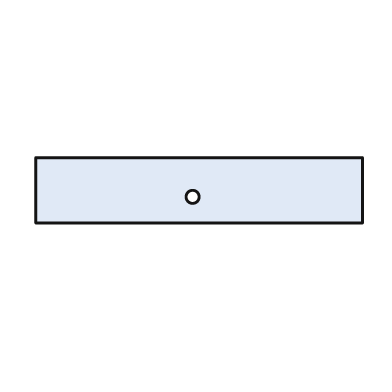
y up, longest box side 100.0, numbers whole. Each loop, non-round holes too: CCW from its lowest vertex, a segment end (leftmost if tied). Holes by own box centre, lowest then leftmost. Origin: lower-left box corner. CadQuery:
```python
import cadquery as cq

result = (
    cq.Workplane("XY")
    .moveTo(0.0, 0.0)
    .lineTo(100.0, 0.0)
    .lineTo(100.0, 20.0)
    .lineTo(0.0, 20.0)
    .close()
    .moveTo(48.0, 8.0)
    .circle(2.0)
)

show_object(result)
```